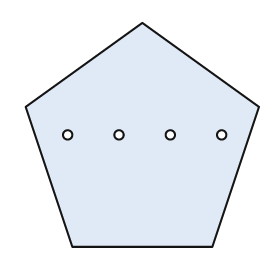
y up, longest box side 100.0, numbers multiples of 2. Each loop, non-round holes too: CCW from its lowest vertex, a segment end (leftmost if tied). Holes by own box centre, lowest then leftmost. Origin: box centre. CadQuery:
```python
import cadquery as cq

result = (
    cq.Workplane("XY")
    .moveTo(-30.0, -48.0)
    .lineTo(30.0, -48.0)
    .lineTo(50.0, 12.0)
    .lineTo(0.0, 48.0)
    .lineTo(-50.0, 12.0)
    .close()
    .moveTo(-32.0, 0.0)
    .circle(2.0)
    .moveTo(-10.0, 0.0)
    .circle(2.0)
    .moveTo(12.0, 0.0)
    .circle(2.0)
    .moveTo(34.0, 0.0)
    .circle(2.0)
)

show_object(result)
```